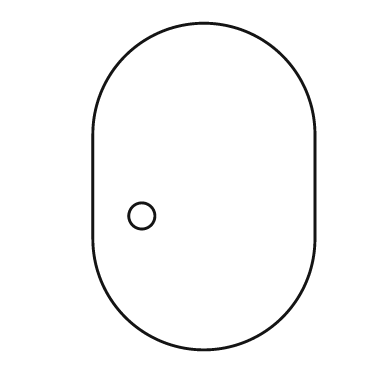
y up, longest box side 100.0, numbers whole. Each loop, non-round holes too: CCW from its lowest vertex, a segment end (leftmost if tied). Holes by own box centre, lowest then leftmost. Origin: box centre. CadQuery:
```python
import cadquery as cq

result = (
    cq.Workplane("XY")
    .moveTo(-34.0, -16.0)
    .threePointArc((0.0, -50.0), (34.0, -16.0))
    .lineTo(34.0, 16.0)
    .threePointArc((0.0, 50.0), (-34.0, 16.0))
    .close()
    .moveTo(-19.0, -9.0)
    .circle(4.0)
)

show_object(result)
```